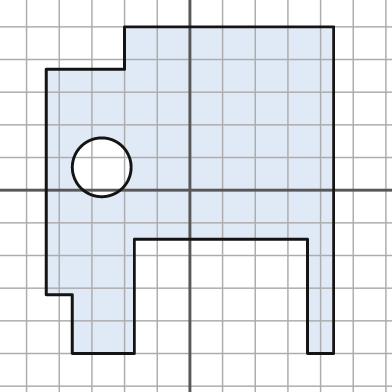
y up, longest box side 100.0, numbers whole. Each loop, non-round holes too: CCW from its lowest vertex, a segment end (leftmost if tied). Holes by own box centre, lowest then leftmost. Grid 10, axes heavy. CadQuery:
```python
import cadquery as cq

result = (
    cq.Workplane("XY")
    .moveTo(-36.0, -50.0)
    .lineTo(-17.0, -50.0)
    .lineTo(-17.0, -15.0)
    .lineTo(36.0, -15.0)
    .lineTo(36.0, -50.0)
    .lineTo(44.0, -50.0)
    .lineTo(44.0, 50.0)
    .lineTo(-20.0, 50.0)
    .lineTo(-20.0, 37.0)
    .lineTo(-44.0, 37.0)
    .lineTo(-44.0, -32.0)
    .lineTo(-36.0, -32.0)
    .close()
    .moveTo(-27.0, 7.0)
    .circle(9.0)
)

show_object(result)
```